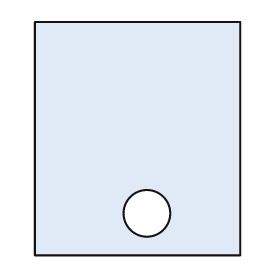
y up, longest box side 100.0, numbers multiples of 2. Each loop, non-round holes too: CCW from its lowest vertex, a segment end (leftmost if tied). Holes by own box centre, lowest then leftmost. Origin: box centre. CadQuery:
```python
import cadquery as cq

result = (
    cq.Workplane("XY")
    .moveTo(-44.0, -50.0)
    .lineTo(44.0, -50.0)
    .lineTo(44.0, 50.0)
    .lineTo(-44.0, 50.0)
    .close()
    .moveTo(4.0, -32.0)
    .circle(10.0)
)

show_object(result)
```